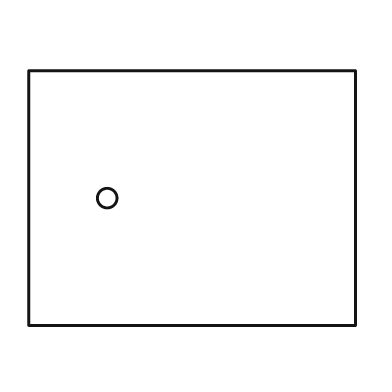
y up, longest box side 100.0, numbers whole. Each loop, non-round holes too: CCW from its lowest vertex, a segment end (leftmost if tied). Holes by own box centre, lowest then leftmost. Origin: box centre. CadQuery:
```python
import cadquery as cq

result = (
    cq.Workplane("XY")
    .moveTo(-50.0, -39.0)
    .lineTo(50.0, -39.0)
    .lineTo(50.0, 39.0)
    .lineTo(-50.0, 39.0)
    .close()
    .moveTo(-26.0, 0.0)
    .circle(3.0)
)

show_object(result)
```